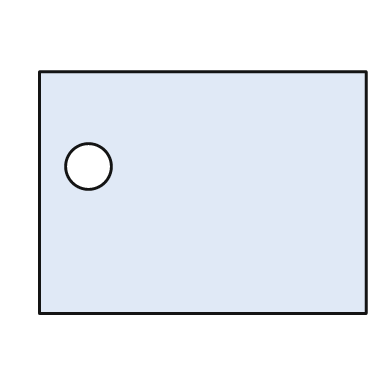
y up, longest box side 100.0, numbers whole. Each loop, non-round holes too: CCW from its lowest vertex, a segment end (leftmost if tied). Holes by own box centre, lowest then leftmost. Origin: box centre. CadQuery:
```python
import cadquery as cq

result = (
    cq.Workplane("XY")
    .moveTo(-50.0, -37.0)
    .lineTo(50.0, -37.0)
    .lineTo(50.0, 37.0)
    .lineTo(-50.0, 37.0)
    .close()
    .moveTo(-35.0, 8.0)
    .circle(7.0)
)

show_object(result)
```